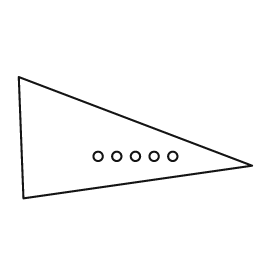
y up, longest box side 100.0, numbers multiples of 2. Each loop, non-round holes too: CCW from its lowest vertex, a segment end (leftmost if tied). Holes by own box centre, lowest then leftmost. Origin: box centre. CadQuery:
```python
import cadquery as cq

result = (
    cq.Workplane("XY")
    .moveTo(-48.0, -26.0)
    .lineTo(50.0, -12.0)
    .lineTo(-50.0, 26.0)
    .close()
    .moveTo(-16.0, -8.0)
    .circle(2.0)
    .moveTo(-8.0, -8.0)
    .circle(2.0)
    .moveTo(0.0, -8.0)
    .circle(2.0)
    .moveTo(8.0, -8.0)
    .circle(2.0)
    .moveTo(16.0, -8.0)
    .circle(2.0)
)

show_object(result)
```